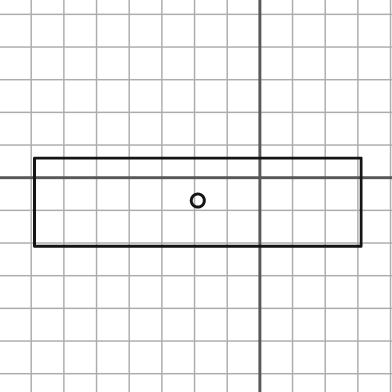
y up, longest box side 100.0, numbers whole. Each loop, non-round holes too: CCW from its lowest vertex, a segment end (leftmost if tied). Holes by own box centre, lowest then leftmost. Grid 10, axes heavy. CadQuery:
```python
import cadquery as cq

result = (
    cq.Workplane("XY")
    .moveTo(-69.0, -21.0)
    .lineTo(31.0, -21.0)
    .lineTo(31.0, 6.0)
    .lineTo(-69.0, 6.0)
    .close()
    .moveTo(-19.0, -7.0)
    .circle(2.0)
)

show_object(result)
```